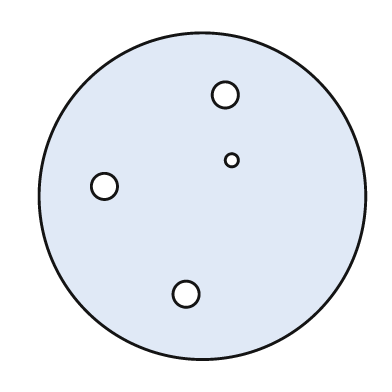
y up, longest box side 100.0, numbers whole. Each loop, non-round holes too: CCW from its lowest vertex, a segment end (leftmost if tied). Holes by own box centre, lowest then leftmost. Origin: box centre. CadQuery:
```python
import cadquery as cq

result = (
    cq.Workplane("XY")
    .moveTo(0.0, 0.0)
    .circle(50.0)
    .moveTo(-5.0, -30.0)
    .circle(4.0)
    .moveTo(-30.0, 3.0)
    .circle(4.0)
    .moveTo(9.0, 11.0)
    .circle(2.0)
    .moveTo(7.0, 31.0)
    .circle(4.0)
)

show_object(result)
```